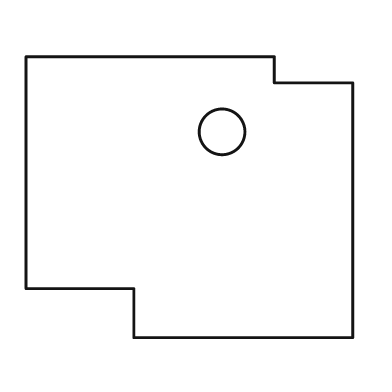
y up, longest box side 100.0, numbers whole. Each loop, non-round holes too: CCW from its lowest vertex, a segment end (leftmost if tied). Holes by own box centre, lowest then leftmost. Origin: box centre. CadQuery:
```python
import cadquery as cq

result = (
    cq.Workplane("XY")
    .moveTo(-17.0, -43.0)
    .lineTo(50.0, -43.0)
    .lineTo(50.0, 35.0)
    .lineTo(26.0, 35.0)
    .lineTo(26.0, 43.0)
    .lineTo(-50.0, 43.0)
    .lineTo(-50.0, -28.0)
    .lineTo(-17.0, -28.0)
    .close()
    .moveTo(10.0, 20.0)
    .circle(7.0)
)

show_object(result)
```